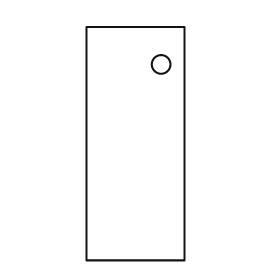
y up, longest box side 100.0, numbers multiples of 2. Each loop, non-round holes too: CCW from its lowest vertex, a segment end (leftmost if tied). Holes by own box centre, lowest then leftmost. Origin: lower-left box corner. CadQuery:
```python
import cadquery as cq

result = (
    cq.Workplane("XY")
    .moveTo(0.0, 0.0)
    .lineTo(42.0, 0.0)
    .lineTo(42.0, 100.0)
    .lineTo(0.0, 100.0)
    .close()
    .moveTo(32.0, 84.0)
    .circle(4.0)
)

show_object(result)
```